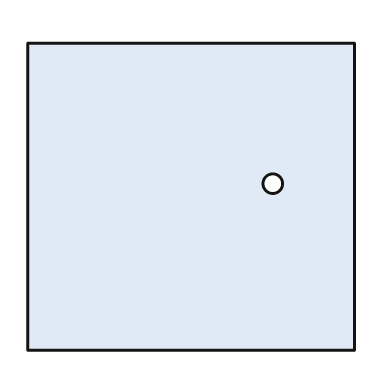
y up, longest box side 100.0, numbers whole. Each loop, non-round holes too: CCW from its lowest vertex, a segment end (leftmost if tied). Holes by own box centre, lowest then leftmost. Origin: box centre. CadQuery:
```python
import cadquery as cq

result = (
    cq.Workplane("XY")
    .moveTo(-50.0, -47.0)
    .lineTo(50.0, -47.0)
    .lineTo(50.0, 47.0)
    .lineTo(-50.0, 47.0)
    .close()
    .moveTo(25.0, 4.0)
    .circle(3.0)
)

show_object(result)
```